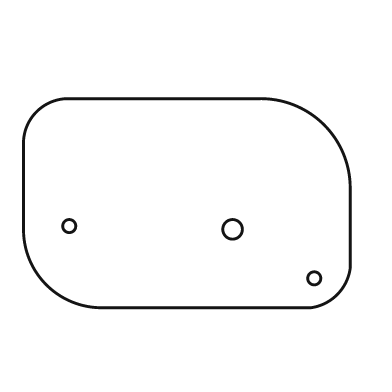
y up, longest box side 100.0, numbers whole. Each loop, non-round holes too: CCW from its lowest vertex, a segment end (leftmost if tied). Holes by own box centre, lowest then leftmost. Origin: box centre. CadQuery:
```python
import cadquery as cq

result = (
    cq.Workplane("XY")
    .moveTo(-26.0, -32.0)
    .lineTo(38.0, -32.0)
    .threePointArc((46.0, -28.0), (50.0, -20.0))
    .lineTo(50.0, 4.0)
    .threePointArc((42.0, 24.0), (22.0, 32.0))
    .lineTo(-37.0, 32.0)
    .threePointArc((-46.0, 28.0), (-50.0, 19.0))
    .lineTo(-50.0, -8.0)
    .threePointArc((-43.0, -25.0), (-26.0, -32.0))
    .close()
    .moveTo(39.0, -23.0)
    .circle(2.0)
    .moveTo(14.0, -8.0)
    .circle(3.0)
    .moveTo(-36.0, -7.0)
    .circle(2.0)
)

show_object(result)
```